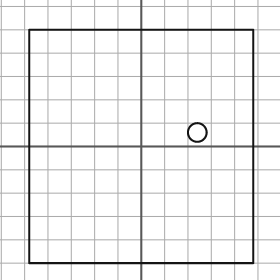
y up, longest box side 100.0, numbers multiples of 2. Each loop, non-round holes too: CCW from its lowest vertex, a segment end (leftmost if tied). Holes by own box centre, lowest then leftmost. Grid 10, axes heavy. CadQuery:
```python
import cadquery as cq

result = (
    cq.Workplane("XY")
    .moveTo(-48.0, -50.0)
    .lineTo(48.0, -50.0)
    .lineTo(48.0, 50.0)
    .lineTo(-48.0, 50.0)
    .close()
    .moveTo(24.0, 6.0)
    .circle(4.0)
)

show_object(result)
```